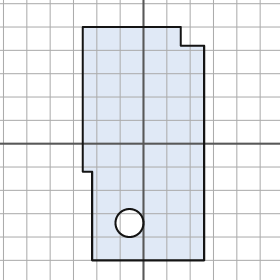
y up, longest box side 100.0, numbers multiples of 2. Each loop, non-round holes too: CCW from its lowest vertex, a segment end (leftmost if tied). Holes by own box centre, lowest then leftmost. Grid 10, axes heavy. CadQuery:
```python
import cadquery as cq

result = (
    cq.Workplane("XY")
    .moveTo(-22.0, -50.0)
    .lineTo(26.0, -50.0)
    .lineTo(26.0, 42.0)
    .lineTo(16.0, 42.0)
    .lineTo(16.0, 50.0)
    .lineTo(-26.0, 50.0)
    .lineTo(-26.0, -12.0)
    .lineTo(-22.0, -12.0)
    .close()
    .moveTo(-6.0, -34.0)
    .circle(6.0)
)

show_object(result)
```